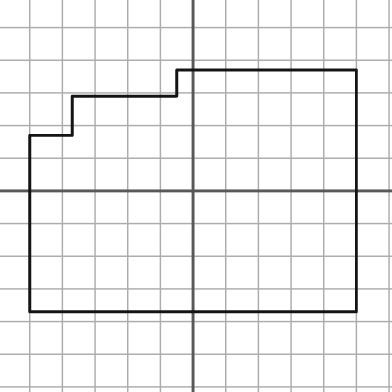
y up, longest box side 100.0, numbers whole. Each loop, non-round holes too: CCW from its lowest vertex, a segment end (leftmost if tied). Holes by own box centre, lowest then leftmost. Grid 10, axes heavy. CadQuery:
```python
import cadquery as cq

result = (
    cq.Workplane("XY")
    .moveTo(-50.0, -37.0)
    .lineTo(50.0, -37.0)
    .lineTo(50.0, 37.0)
    .lineTo(-5.0, 37.0)
    .lineTo(-5.0, 29.0)
    .lineTo(-37.0, 29.0)
    .lineTo(-37.0, 17.0)
    .lineTo(-50.0, 17.0)
    .close()
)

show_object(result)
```